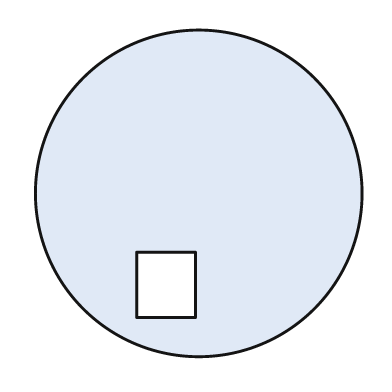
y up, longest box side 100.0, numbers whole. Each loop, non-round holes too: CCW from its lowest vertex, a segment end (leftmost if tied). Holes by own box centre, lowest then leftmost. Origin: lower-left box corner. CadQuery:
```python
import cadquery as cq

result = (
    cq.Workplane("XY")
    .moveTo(50.0, 50.0)
    .circle(50.0)
    .moveTo(31.0, 12.0)
    .lineTo(49.0, 12.0)
    .lineTo(49.0, 32.0)
    .lineTo(31.0, 32.0)
    .close()
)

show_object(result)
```